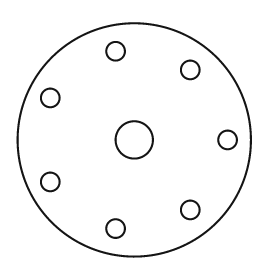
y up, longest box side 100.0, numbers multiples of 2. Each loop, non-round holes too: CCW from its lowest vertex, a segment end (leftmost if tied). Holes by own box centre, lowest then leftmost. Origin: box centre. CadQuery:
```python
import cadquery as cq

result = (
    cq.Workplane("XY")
    .moveTo(0.0, 0.0)
    .circle(50.0)
    .moveTo(-8.0, -38.0)
    .circle(4.0)
    .moveTo(24.0, -30.0)
    .circle(4.0)
    .moveTo(-36.0, -18.0)
    .circle(4.0)
    .moveTo(0.0, 0.0)
    .circle(8.0)
    .moveTo(40.0, 0.0)
    .circle(4.0)
    .moveTo(-36.0, 18.0)
    .circle(4.0)
    .moveTo(24.0, 30.0)
    .circle(4.0)
    .moveTo(-8.0, 38.0)
    .circle(4.0)
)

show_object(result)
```